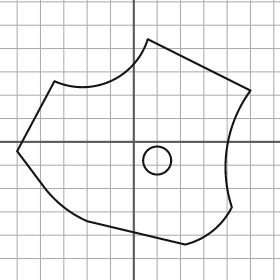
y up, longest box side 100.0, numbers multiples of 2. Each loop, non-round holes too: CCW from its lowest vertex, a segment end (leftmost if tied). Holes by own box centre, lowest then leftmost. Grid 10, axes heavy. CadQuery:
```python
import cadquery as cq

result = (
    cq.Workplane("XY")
    .moveTo(22.0, -44.0)
    .threePointArc((34.0, -38.0), (42.0, -28.0))
    .threePointArc((40.0, -2.0), (50.0, 22.0))
    .lineTo(6.0, 44.0)
    .threePointArc((-10.0, 26.0), (-34.0, 26.0))
    .lineTo(-50.0, -4.0)
    .lineTo(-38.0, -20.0)
    .threePointArc((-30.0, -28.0), (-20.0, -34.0))
    .close()
    .moveTo(10.0, -8.0)
    .circle(6.0)
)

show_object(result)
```